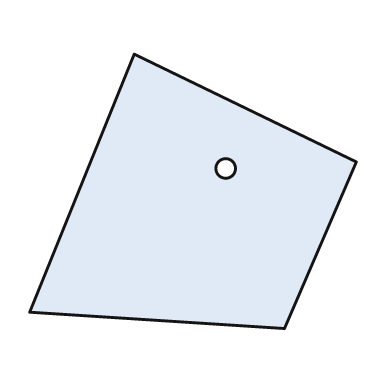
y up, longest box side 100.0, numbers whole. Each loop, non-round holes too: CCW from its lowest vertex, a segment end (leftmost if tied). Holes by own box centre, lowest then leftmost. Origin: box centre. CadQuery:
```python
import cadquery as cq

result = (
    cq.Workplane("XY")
    .moveTo(28.0, -42.0)
    .lineTo(50.0, 9.0)
    .lineTo(-18.0, 42.0)
    .lineTo(-50.0, -37.0)
    .close()
    .moveTo(10.0, 7.0)
    .circle(3.0)
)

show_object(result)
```